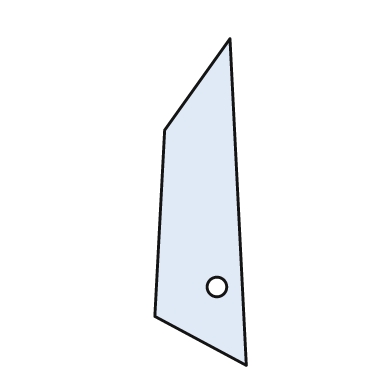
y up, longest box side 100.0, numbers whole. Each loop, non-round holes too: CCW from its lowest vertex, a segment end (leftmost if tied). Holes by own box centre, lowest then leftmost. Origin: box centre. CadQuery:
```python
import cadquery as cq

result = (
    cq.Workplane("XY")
    .moveTo(14.0, -50.0)
    .lineTo(9.0, 50.0)
    .lineTo(-11.0, 22.0)
    .lineTo(-14.0, -35.0)
    .close()
    .moveTo(5.0, -26.0)
    .circle(3.0)
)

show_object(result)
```